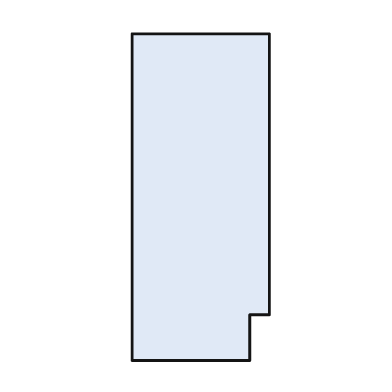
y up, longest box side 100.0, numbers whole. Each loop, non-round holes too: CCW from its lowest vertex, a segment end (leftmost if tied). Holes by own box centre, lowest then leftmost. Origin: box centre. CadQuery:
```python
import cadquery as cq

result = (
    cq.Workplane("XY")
    .moveTo(-21.0, -50.0)
    .lineTo(15.0, -50.0)
    .lineTo(15.0, -36.0)
    .lineTo(21.0, -36.0)
    .lineTo(21.0, 50.0)
    .lineTo(-21.0, 50.0)
    .close()
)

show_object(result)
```